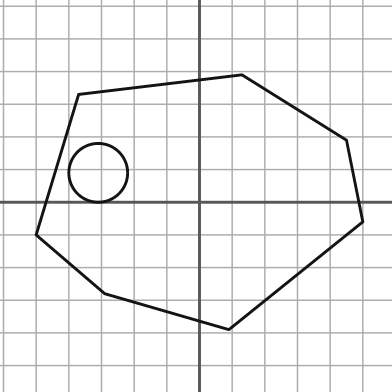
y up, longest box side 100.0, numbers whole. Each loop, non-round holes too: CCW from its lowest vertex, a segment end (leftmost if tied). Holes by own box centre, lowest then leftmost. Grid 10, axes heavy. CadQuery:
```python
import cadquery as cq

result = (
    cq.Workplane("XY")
    .moveTo(9.0, -39.0)
    .lineTo(50.0, -6.0)
    .lineTo(45.0, 19.0)
    .lineTo(13.0, 39.0)
    .lineTo(-37.0, 33.0)
    .lineTo(-50.0, -10.0)
    .lineTo(-29.0, -28.0)
    .close()
    .moveTo(-31.0, 9.0)
    .circle(9.0)
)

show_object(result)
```